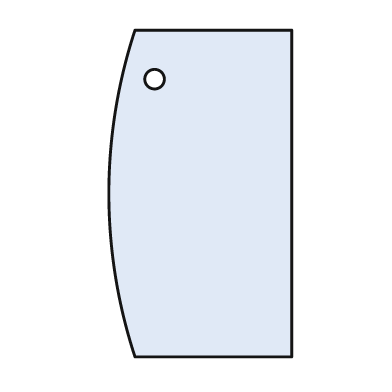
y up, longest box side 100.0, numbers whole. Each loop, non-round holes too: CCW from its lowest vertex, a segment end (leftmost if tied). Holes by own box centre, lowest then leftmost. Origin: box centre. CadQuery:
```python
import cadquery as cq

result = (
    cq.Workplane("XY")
    .moveTo(-20.0, -50.0)
    .lineTo(28.0, -50.0)
    .lineTo(28.0, 50.0)
    .lineTo(-20.0, 50.0)
    .threePointArc((-28.0, 0.0), (-20.0, -50.0))
    .close()
    .moveTo(-14.0, 35.0)
    .circle(3.0)
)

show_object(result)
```